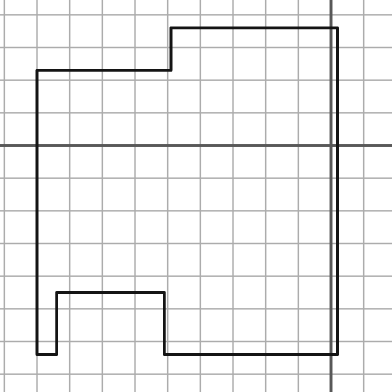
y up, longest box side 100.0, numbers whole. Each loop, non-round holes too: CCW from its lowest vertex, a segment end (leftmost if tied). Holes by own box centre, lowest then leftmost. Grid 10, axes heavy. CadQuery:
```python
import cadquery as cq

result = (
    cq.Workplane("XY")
    .moveTo(-90.0, -64.0)
    .lineTo(-84.0, -64.0)
    .lineTo(-84.0, -45.0)
    .lineTo(-51.0, -45.0)
    .lineTo(-51.0, -64.0)
    .lineTo(2.0, -64.0)
    .lineTo(2.0, 36.0)
    .lineTo(-49.0, 36.0)
    .lineTo(-49.0, 23.0)
    .lineTo(-90.0, 23.0)
    .close()
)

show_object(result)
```